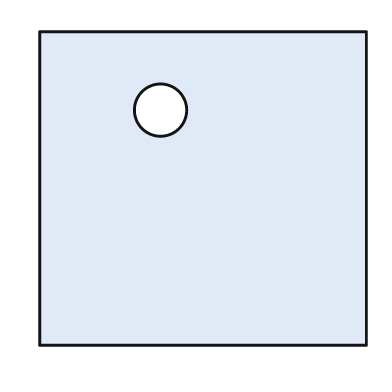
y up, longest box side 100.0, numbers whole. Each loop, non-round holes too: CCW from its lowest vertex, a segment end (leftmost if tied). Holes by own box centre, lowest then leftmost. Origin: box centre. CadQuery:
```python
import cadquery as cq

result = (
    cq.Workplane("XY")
    .moveTo(-50.0, -48.0)
    .lineTo(50.0, -48.0)
    .lineTo(50.0, 48.0)
    .lineTo(-50.0, 48.0)
    .close()
    .moveTo(-13.0, 24.0)
    .circle(8.0)
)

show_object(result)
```